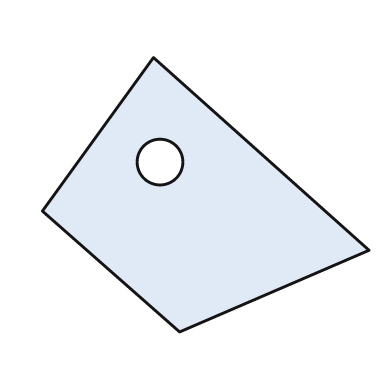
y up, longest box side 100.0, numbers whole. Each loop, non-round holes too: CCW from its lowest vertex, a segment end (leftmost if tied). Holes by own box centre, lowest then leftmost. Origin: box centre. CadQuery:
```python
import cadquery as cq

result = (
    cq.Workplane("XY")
    .moveTo(-8.0, -42.0)
    .lineTo(50.0, -17.0)
    .lineTo(-16.0, 42.0)
    .lineTo(-50.0, -5.0)
    .close()
    .moveTo(-14.0, 10.0)
    .circle(7.0)
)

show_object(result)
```